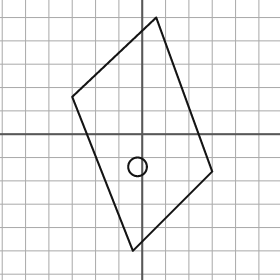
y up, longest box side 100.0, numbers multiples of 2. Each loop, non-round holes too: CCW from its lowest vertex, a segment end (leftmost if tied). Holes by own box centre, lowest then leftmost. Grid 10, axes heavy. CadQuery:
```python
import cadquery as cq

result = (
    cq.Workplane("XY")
    .moveTo(-4.0, -50.0)
    .lineTo(30.0, -16.0)
    .lineTo(6.0, 50.0)
    .lineTo(-30.0, 16.0)
    .close()
    .moveTo(-2.0, -14.0)
    .circle(4.0)
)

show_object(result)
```